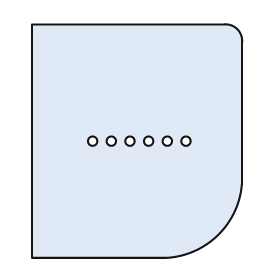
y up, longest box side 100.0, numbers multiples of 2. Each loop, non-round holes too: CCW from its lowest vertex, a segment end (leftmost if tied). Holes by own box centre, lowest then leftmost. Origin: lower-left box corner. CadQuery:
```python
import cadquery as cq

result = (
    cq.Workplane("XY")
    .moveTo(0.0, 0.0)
    .lineTo(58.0, 0.0)
    .threePointArc((80.0, 10.0), (90.0, 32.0))
    .lineTo(90.0, 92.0)
    .threePointArc((88.0, 98.0), (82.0, 100.0))
    .lineTo(0.0, 100.0)
    .close()
    .moveTo(26.0, 50.0)
    .circle(2.0)
    .moveTo(34.0, 50.0)
    .circle(2.0)
    .moveTo(42.0, 50.0)
    .circle(2.0)
    .moveTo(50.0, 50.0)
    .circle(2.0)
    .moveTo(58.0, 50.0)
    .circle(2.0)
    .moveTo(66.0, 50.0)
    .circle(2.0)
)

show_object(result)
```